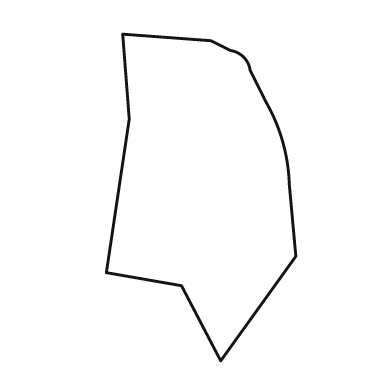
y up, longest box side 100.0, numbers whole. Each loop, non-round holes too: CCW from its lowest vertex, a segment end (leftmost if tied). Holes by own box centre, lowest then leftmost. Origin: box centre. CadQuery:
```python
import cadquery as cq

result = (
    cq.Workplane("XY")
    .moveTo(6.0, -50.0)
    .lineTo(29.0, -18.0)
    .lineTo(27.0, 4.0)
    .threePointArc((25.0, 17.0), (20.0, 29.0))
    .lineTo(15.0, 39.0)
    .threePointArc((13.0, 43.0), (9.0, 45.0))
    .lineTo(3.0, 48.0)
    .lineTo(-24.0, 50.0)
    .lineTo(-22.0, 24.0)
    .lineTo(-29.0, -23.0)
    .lineTo(-6.0, -27.0)
    .close()
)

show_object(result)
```